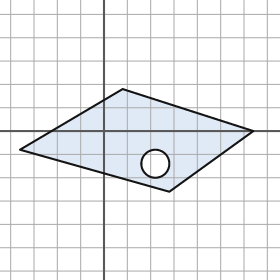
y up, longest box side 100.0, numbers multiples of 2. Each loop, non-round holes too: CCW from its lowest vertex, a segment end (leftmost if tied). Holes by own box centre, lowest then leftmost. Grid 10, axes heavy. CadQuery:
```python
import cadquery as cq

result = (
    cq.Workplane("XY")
    .moveTo(28.0, -26.0)
    .lineTo(64.0, 0.0)
    .lineTo(8.0, 18.0)
    .lineTo(-36.0, -8.0)
    .close()
    .moveTo(22.0, -14.0)
    .circle(6.0)
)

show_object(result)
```